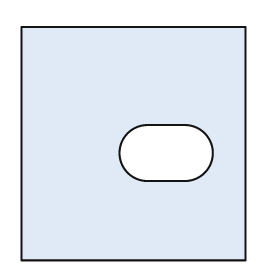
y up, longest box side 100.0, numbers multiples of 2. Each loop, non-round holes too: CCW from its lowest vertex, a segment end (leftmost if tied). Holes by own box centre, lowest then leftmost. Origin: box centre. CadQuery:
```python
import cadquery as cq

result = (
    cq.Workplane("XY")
    .moveTo(-48.0, -50.0)
    .lineTo(48.0, -50.0)
    .lineTo(48.0, 50.0)
    .lineTo(-48.0, 50.0)
    .close()
    .moveTo(6.0, -16.0)
    .lineTo(22.0, -16.0)
    .threePointArc((34.0, -4.0), (22.0, 8.0))
    .lineTo(6.0, 8.0)
    .threePointArc((-6.0, -4.0), (6.0, -16.0))
    .close()
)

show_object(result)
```